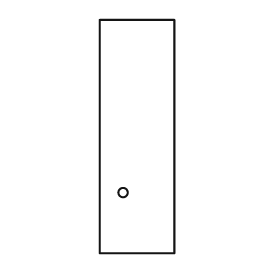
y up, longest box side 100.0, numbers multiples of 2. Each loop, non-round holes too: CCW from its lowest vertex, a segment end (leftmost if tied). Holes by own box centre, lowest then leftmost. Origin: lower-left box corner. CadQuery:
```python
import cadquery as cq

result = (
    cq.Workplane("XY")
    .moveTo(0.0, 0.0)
    .lineTo(32.0, 0.0)
    .lineTo(32.0, 100.0)
    .lineTo(0.0, 100.0)
    .close()
    .moveTo(10.0, 26.0)
    .circle(2.0)
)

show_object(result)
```